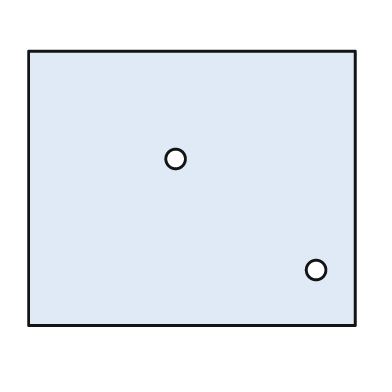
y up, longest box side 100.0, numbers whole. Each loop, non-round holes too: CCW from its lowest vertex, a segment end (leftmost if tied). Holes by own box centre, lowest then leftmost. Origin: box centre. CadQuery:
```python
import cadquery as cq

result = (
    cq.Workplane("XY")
    .moveTo(-50.0, -42.0)
    .lineTo(50.0, -42.0)
    .lineTo(50.0, 42.0)
    .lineTo(-50.0, 42.0)
    .close()
    .moveTo(38.0, -25.0)
    .circle(3.0)
    .moveTo(-5.0, 9.0)
    .circle(3.0)
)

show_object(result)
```